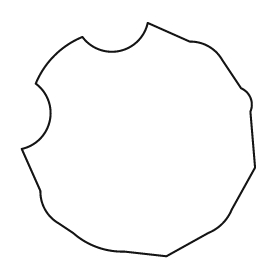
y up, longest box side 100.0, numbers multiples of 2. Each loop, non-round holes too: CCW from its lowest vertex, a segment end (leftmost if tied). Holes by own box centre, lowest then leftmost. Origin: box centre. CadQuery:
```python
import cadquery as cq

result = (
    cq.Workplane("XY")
    .moveTo(12.0, -50.0)
    .lineTo(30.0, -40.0)
    .threePointArc((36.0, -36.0), (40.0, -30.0))
    .lineTo(50.0, -12.0)
    .lineTo(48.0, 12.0)
    .threePointArc((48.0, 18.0), (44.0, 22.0))
    .lineTo(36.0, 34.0)
    .threePointArc((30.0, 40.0), (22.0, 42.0))
    .lineTo(4.0, 50.0)
    .threePointArc((-8.0, 38.0), (-24.0, 44.0))
    .threePointArc((-36.0, 36.0), (-44.0, 24.0))
    .threePointArc((-38.0, 8.0), (-50.0, -4.0))
    .lineTo(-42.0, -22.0)
    .threePointArc((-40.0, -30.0), (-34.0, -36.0))
    .lineTo(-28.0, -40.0)
    .threePointArc((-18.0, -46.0), (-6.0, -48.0))
    .close()
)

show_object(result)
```